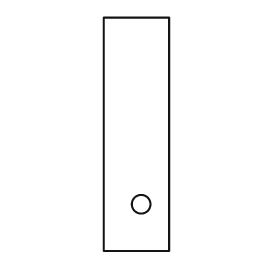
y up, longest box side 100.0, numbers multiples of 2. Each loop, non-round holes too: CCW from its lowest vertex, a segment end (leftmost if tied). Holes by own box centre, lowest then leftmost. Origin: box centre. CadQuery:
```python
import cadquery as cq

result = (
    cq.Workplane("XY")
    .moveTo(-14.0, -50.0)
    .lineTo(14.0, -50.0)
    .lineTo(14.0, 50.0)
    .lineTo(-14.0, 50.0)
    .close()
    .moveTo(2.0, -30.0)
    .circle(4.0)
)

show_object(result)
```